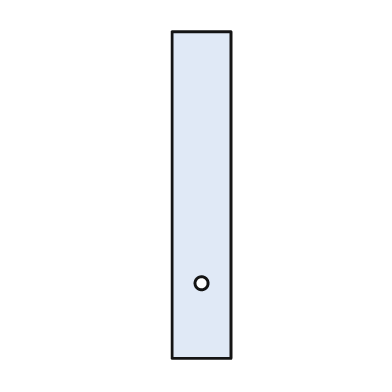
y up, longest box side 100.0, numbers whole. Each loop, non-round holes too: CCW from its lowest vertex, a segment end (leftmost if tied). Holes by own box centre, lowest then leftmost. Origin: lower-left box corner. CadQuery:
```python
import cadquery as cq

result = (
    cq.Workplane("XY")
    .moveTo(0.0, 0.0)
    .lineTo(18.0, 0.0)
    .lineTo(18.0, 100.0)
    .lineTo(0.0, 100.0)
    .close()
    .moveTo(9.0, 23.0)
    .circle(2.0)
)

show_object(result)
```